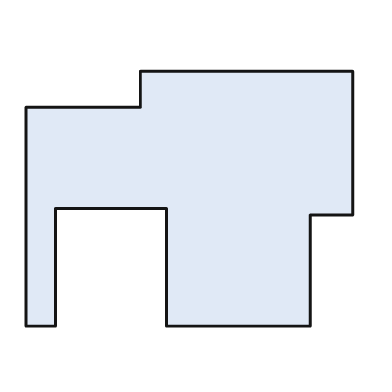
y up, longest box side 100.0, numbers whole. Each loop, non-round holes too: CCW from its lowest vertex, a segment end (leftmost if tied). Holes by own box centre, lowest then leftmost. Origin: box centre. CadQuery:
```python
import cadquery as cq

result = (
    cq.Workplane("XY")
    .moveTo(-50.0, -39.0)
    .lineTo(-41.0, -39.0)
    .lineTo(-41.0, -3.0)
    .lineTo(-7.0, -3.0)
    .lineTo(-7.0, -39.0)
    .lineTo(37.0, -39.0)
    .lineTo(37.0, -5.0)
    .lineTo(50.0, -5.0)
    .lineTo(50.0, 39.0)
    .lineTo(-15.0, 39.0)
    .lineTo(-15.0, 28.0)
    .lineTo(-50.0, 28.0)
    .close()
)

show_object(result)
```